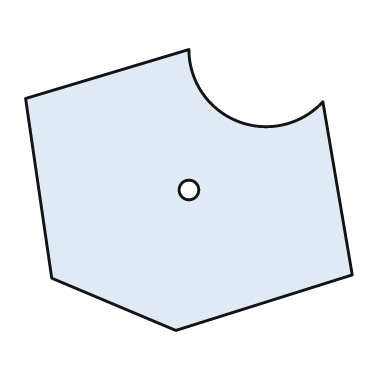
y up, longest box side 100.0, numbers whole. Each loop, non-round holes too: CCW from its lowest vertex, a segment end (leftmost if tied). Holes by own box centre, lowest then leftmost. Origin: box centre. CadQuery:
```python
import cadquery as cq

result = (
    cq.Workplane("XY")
    .moveTo(-4.0, -43.0)
    .lineTo(50.0, -26.0)
    .lineTo(41.0, 27.0)
    .threePointArc((15.0, 21.0), (0.0, 43.0))
    .lineTo(-50.0, 28.0)
    .lineTo(-42.0, -27.0)
    .close()
    .moveTo(0.0, 0.0)
    .circle(3.0)
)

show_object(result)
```